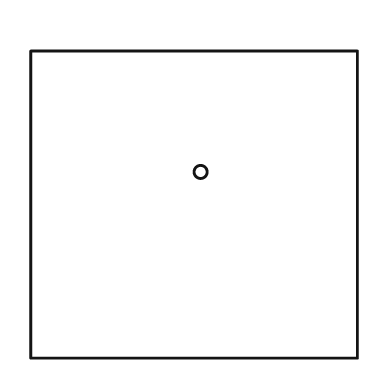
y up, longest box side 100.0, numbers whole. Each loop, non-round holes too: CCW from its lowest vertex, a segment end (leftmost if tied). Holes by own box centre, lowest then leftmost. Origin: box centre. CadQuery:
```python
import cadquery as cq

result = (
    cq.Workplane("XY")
    .moveTo(-50.0, -47.0)
    .lineTo(50.0, -47.0)
    .lineTo(50.0, 47.0)
    .lineTo(-50.0, 47.0)
    .close()
    .moveTo(2.0, 10.0)
    .circle(2.0)
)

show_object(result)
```